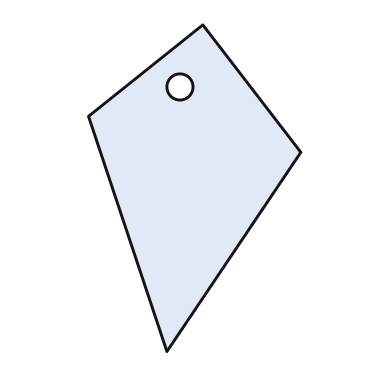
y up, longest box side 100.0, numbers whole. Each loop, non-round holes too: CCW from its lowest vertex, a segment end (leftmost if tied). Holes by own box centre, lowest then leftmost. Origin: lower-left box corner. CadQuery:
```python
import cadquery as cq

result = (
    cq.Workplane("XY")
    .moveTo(24.0, 0.0)
    .lineTo(65.0, 61.0)
    .lineTo(35.0, 100.0)
    .lineTo(0.0, 72.0)
    .close()
    .moveTo(28.0, 81.0)
    .circle(4.0)
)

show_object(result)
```